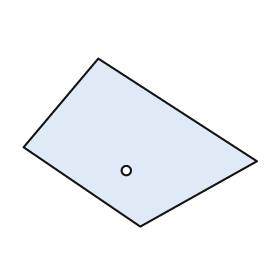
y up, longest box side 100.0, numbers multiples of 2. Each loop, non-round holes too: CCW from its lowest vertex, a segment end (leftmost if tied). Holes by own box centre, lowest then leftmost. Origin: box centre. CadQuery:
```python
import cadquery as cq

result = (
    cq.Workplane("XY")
    .moveTo(0.0, -36.0)
    .lineTo(50.0, -8.0)
    .lineTo(-18.0, 36.0)
    .lineTo(-50.0, -2.0)
    .close()
    .moveTo(-6.0, -12.0)
    .circle(2.0)
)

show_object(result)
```